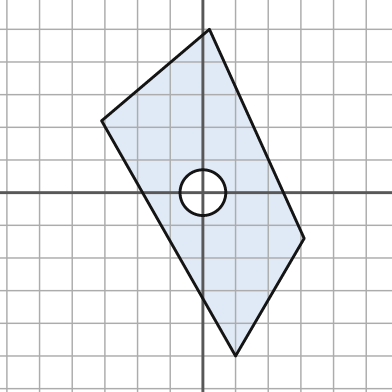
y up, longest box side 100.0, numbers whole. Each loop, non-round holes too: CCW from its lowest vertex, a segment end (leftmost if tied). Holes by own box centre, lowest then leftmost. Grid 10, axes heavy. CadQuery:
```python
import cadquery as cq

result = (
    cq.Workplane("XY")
    .moveTo(10.0, -50.0)
    .lineTo(31.0, -14.0)
    .lineTo(2.0, 50.0)
    .lineTo(-31.0, 22.0)
    .close()
    .moveTo(0.0, 0.0)
    .circle(7.0)
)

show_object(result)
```